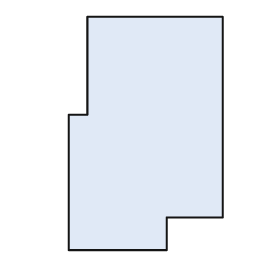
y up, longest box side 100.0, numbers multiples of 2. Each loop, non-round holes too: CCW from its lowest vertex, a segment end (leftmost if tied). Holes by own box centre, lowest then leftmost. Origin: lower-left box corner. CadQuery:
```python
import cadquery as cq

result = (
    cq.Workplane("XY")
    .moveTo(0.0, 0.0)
    .lineTo(42.0, 0.0)
    .lineTo(42.0, 14.0)
    .lineTo(66.0, 14.0)
    .lineTo(66.0, 100.0)
    .lineTo(8.0, 100.0)
    .lineTo(8.0, 58.0)
    .lineTo(0.0, 58.0)
    .close()
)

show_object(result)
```